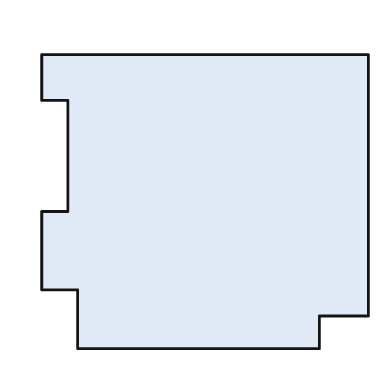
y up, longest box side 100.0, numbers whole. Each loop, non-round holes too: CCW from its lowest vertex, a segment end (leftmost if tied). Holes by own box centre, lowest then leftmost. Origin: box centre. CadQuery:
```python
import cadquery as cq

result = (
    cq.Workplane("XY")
    .moveTo(-39.0, -45.0)
    .lineTo(35.0, -45.0)
    .lineTo(35.0, -35.0)
    .lineTo(50.0, -35.0)
    .lineTo(50.0, 45.0)
    .lineTo(-50.0, 45.0)
    .lineTo(-50.0, 31.0)
    .lineTo(-42.0, 31.0)
    .lineTo(-42.0, -3.0)
    .lineTo(-50.0, -3.0)
    .lineTo(-50.0, -27.0)
    .lineTo(-39.0, -27.0)
    .close()
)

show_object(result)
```